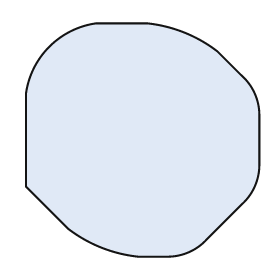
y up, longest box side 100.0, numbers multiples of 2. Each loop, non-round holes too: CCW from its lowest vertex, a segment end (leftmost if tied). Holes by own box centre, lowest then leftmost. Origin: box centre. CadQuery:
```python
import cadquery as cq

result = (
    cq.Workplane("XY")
    .moveTo(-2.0, -50.0)
    .lineTo(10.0, -50.0)
    .threePointArc((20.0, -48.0), (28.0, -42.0))
    .lineTo(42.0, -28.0)
    .threePointArc((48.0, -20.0), (50.0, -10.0))
    .lineTo(50.0, 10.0)
    .threePointArc((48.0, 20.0), (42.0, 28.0))
    .lineTo(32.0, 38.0)
    .threePointArc((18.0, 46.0), (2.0, 50.0))
    .lineTo(-20.0, 50.0)
    .threePointArc((-40.0, 40.0), (-50.0, 20.0))
    .lineTo(-50.0, -20.0)
    .lineTo(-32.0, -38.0)
    .threePointArc((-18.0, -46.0), (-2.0, -50.0))
    .close()
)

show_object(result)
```